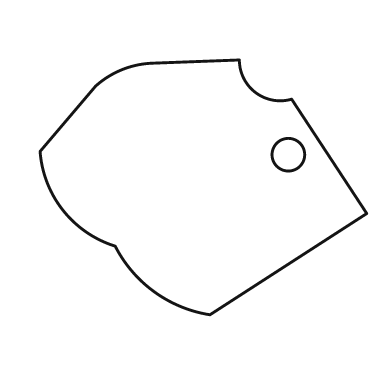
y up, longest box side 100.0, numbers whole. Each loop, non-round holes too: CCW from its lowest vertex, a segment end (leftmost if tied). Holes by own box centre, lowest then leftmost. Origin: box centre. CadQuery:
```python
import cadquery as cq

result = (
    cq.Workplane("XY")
    .moveTo(2.0, -39.0)
    .lineTo(50.0, -8.0)
    .lineTo(27.0, 27.0)
    .threePointArc((16.0, 29.0), (11.0, 39.0))
    .lineTo(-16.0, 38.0)
    .threePointArc((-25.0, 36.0), (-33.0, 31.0))
    .lineTo(-50.0, 11.0)
    .threePointArc((-43.0, -7.0), (-27.0, -18.0))
    .threePointArc((-15.0, -32.0), (2.0, -39.0))
    .close()
    .moveTo(26.0, 10.0)
    .circle(5.0)
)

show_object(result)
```